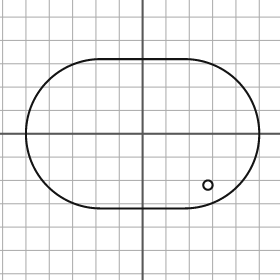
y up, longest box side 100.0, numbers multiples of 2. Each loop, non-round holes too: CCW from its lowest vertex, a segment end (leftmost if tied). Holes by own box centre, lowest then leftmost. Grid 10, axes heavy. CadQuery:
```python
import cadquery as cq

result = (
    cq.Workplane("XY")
    .moveTo(-18.0, -32.0)
    .lineTo(18.0, -32.0)
    .threePointArc((50.0, 0.0), (18.0, 32.0))
    .lineTo(-18.0, 32.0)
    .threePointArc((-50.0, 0.0), (-18.0, -32.0))
    .close()
    .moveTo(28.0, -22.0)
    .circle(2.0)
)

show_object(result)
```